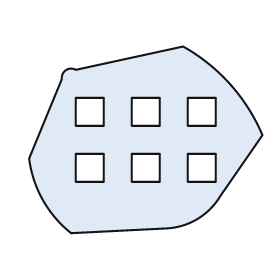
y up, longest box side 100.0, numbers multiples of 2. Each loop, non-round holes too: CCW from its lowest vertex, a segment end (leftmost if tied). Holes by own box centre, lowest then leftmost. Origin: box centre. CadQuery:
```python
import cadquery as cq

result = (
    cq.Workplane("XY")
    .moveTo(-32.0, -40.0)
    .lineTo(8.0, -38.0)
    .threePointArc((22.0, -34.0), (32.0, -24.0))
    .lineTo(50.0, 2.0)
    .threePointArc((36.0, 24.0), (16.0, 40.0))
    .lineTo(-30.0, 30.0)
    .threePointArc((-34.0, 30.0), (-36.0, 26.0))
    .lineTo(-50.0, -8.0)
    .threePointArc((-44.0, -26.0), (-32.0, -40.0))
    .close()
    .moveTo(-30.0, -18.0)
    .lineTo(-18.0, -18.0)
    .lineTo(-18.0, -6.0)
    .lineTo(-30.0, -6.0)
    .close()
    .moveTo(-6.0, -18.0)
    .lineTo(6.0, -18.0)
    .lineTo(6.0, -6.0)
    .lineTo(-6.0, -6.0)
    .close()
    .moveTo(18.0, -18.0)
    .lineTo(30.0, -18.0)
    .lineTo(30.0, -6.0)
    .lineTo(18.0, -6.0)
    .close()
    .moveTo(-30.0, 6.0)
    .lineTo(-18.0, 6.0)
    .lineTo(-18.0, 18.0)
    .lineTo(-30.0, 18.0)
    .close()
    .moveTo(-6.0, 6.0)
    .lineTo(6.0, 6.0)
    .lineTo(6.0, 18.0)
    .lineTo(-6.0, 18.0)
    .close()
    .moveTo(18.0, 6.0)
    .lineTo(30.0, 6.0)
    .lineTo(30.0, 18.0)
    .lineTo(18.0, 18.0)
    .close()
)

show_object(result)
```